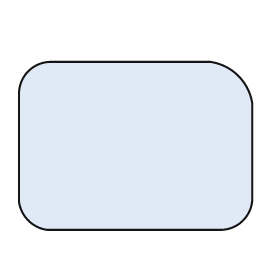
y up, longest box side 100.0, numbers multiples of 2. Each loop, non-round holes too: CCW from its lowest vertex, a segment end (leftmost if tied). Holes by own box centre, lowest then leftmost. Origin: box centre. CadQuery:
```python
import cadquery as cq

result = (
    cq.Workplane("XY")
    .moveTo(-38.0, -36.0)
    .lineTo(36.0, -36.0)
    .threePointArc((46.0, -32.0), (50.0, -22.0))
    .lineTo(50.0, 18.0)
    .threePointArc((44.0, 30.0), (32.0, 36.0))
    .lineTo(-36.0, 36.0)
    .threePointArc((-46.0, 32.0), (-50.0, 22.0))
    .lineTo(-50.0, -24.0)
    .threePointArc((-46.0, -32.0), (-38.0, -36.0))
    .close()
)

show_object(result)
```